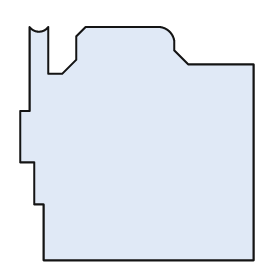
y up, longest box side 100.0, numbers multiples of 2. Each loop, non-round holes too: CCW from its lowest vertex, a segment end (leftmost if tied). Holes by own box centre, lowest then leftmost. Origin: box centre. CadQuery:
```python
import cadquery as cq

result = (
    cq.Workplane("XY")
    .moveTo(-40.0, -50.0)
    .lineTo(50.0, -50.0)
    .lineTo(50.0, 34.0)
    .lineTo(22.0, 34.0)
    .lineTo(16.0, 40.0)
    .lineTo(16.0, 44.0)
    .threePointArc((14.0, 48.0), (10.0, 50.0))
    .lineTo(-22.0, 50.0)
    .lineTo(-26.0, 46.0)
    .lineTo(-26.0, 36.0)
    .lineTo(-32.0, 30.0)
    .lineTo(-38.0, 30.0)
    .lineTo(-38.0, 50.0)
    .threePointArc((-42.0, 48.0), (-46.0, 50.0))
    .lineTo(-46.0, 14.0)
    .lineTo(-50.0, 14.0)
    .lineTo(-50.0, -8.0)
    .lineTo(-44.0, -8.0)
    .lineTo(-44.0, -26.0)
    .lineTo(-40.0, -26.0)
    .close()
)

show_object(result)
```